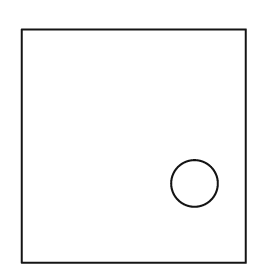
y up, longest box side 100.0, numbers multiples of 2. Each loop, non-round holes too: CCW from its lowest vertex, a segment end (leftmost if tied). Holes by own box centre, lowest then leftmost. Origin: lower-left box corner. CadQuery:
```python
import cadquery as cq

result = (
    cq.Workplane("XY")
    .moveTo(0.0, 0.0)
    .lineTo(96.0, 0.0)
    .lineTo(96.0, 100.0)
    .lineTo(0.0, 100.0)
    .close()
    .moveTo(74.0, 34.0)
    .circle(10.0)
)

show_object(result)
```